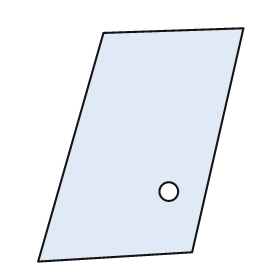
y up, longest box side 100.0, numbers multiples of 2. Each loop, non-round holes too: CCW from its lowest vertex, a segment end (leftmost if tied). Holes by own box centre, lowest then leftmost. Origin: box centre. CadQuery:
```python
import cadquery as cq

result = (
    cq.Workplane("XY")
    .moveTo(-44.0, -50.0)
    .lineTo(22.0, -46.0)
    .lineTo(44.0, 50.0)
    .lineTo(-16.0, 48.0)
    .close()
    .moveTo(12.0, -20.0)
    .circle(4.0)
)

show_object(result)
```